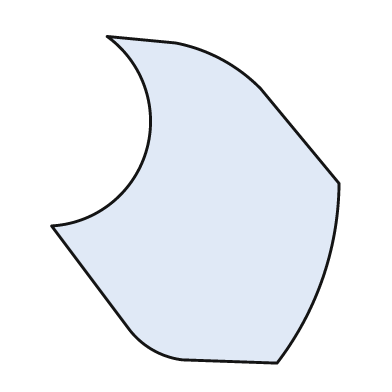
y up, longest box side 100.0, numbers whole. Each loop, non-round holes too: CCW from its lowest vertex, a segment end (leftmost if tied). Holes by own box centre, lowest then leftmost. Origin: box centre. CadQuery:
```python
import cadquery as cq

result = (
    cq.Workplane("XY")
    .moveTo(25.0, -50.0)
    .threePointArc((39.0, -24.0), (44.0, 5.0))
    .lineTo(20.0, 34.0)
    .threePointArc((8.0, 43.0), (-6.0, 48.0))
    .lineTo(-27.0, 50.0)
    .threePointArc((-15.0, 15.0), (-44.0, -8.0))
    .lineTo(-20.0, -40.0)
    .threePointArc((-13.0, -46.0), (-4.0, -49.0))
    .close()
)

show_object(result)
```